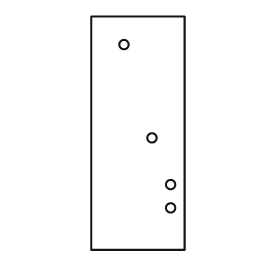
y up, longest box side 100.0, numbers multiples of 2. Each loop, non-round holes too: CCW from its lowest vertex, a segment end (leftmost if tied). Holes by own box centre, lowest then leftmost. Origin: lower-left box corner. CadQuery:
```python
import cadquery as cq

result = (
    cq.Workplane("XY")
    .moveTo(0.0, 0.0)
    .lineTo(40.0, 0.0)
    .lineTo(40.0, 100.0)
    .lineTo(0.0, 100.0)
    .close()
    .moveTo(34.0, 18.0)
    .circle(2.0)
    .moveTo(34.0, 28.0)
    .circle(2.0)
    .moveTo(26.0, 48.0)
    .circle(2.0)
    .moveTo(14.0, 88.0)
    .circle(2.0)
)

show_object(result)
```